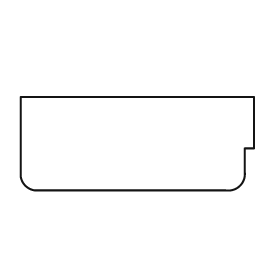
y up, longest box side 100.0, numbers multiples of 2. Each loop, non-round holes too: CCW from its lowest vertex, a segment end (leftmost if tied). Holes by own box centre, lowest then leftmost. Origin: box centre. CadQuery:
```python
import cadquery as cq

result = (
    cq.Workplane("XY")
    .moveTo(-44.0, -20.0)
    .lineTo(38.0, -20.0)
    .threePointArc((44.0, -18.0), (46.0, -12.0))
    .lineTo(46.0, -2.0)
    .lineTo(50.0, -2.0)
    .lineTo(50.0, 20.0)
    .lineTo(-50.0, 20.0)
    .lineTo(-50.0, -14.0)
    .threePointArc((-48.0, -18.0), (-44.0, -20.0))
    .close()
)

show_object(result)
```